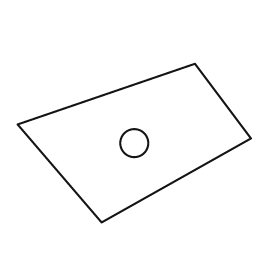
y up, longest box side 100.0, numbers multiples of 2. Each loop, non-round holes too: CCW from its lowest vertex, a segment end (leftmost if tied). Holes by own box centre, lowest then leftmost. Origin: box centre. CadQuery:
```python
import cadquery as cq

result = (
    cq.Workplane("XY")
    .moveTo(-14.0, -34.0)
    .lineTo(50.0, 2.0)
    .lineTo(26.0, 34.0)
    .lineTo(-50.0, 8.0)
    .close()
    .moveTo(0.0, 0.0)
    .circle(6.0)
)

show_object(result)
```